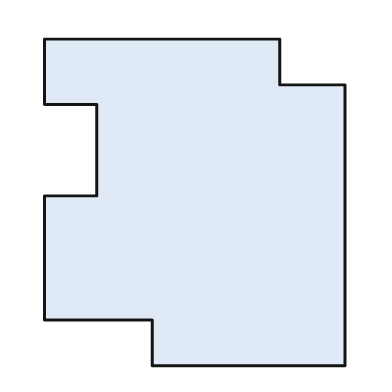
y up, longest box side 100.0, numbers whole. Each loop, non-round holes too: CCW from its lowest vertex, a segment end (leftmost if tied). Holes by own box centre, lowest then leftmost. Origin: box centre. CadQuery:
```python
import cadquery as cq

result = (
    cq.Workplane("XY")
    .moveTo(-13.0, -50.0)
    .lineTo(46.0, -50.0)
    .lineTo(46.0, 36.0)
    .lineTo(26.0, 36.0)
    .lineTo(26.0, 50.0)
    .lineTo(-46.0, 50.0)
    .lineTo(-46.0, 30.0)
    .lineTo(-30.0, 30.0)
    .lineTo(-30.0, 2.0)
    .lineTo(-46.0, 2.0)
    .lineTo(-46.0, -36.0)
    .lineTo(-13.0, -36.0)
    .close()
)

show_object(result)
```